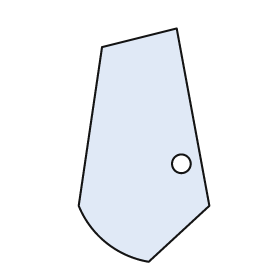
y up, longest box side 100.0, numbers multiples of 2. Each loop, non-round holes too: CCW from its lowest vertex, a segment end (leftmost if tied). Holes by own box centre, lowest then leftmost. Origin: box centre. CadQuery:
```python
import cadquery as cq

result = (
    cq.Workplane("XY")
    .moveTo(2.0, -50.0)
    .lineTo(28.0, -26.0)
    .lineTo(14.0, 50.0)
    .lineTo(-18.0, 42.0)
    .lineTo(-28.0, -26.0)
    .threePointArc((-16.0, -42.0), (2.0, -50.0))
    .close()
    .moveTo(16.0, -8.0)
    .circle(4.0)
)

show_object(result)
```